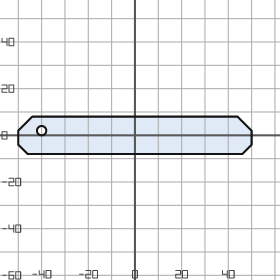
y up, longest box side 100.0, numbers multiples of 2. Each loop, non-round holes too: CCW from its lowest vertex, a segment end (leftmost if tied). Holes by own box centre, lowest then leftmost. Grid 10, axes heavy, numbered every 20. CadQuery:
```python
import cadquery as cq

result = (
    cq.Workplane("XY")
    .moveTo(-46.0, -8.0)
    .lineTo(46.0, -8.0)
    .lineTo(50.0, -4.0)
    .lineTo(50.0, 2.0)
    .lineTo(44.0, 8.0)
    .lineTo(-44.0, 8.0)
    .lineTo(-50.0, 2.0)
    .lineTo(-50.0, -4.0)
    .close()
    .moveTo(-40.0, 2.0)
    .circle(2.0)
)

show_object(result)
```